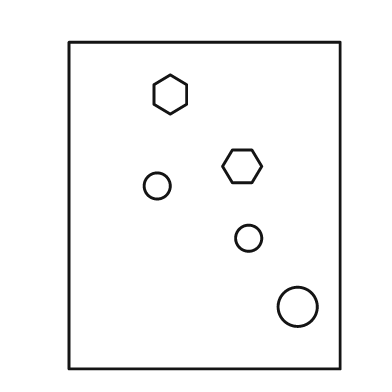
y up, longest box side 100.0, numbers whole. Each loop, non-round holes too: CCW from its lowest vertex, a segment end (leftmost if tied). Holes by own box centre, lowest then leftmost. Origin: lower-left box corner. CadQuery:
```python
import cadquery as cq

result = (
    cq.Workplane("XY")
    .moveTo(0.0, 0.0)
    .lineTo(83.0, 0.0)
    .lineTo(83.0, 100.0)
    .lineTo(0.0, 100.0)
    .close()
    .moveTo(70.0, 19.0)
    .circle(6.0)
    .moveTo(55.0, 40.0)
    .circle(4.0)
    .moveTo(27.0, 56.0)
    .circle(4.0)
    .moveTo(50.0, 57.0)
    .lineTo(56.0, 57.0)
    .lineTo(59.0, 62.0)
    .lineTo(56.0, 67.0)
    .lineTo(50.0, 67.0)
    .lineTo(47.0, 62.0)
    .close()
    .moveTo(31.0, 78.0)
    .lineTo(36.0, 81.0)
    .lineTo(36.0, 87.0)
    .lineTo(31.0, 90.0)
    .lineTo(26.0, 87.0)
    .lineTo(26.0, 81.0)
    .close()
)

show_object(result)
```